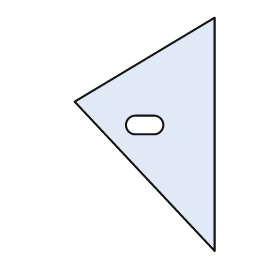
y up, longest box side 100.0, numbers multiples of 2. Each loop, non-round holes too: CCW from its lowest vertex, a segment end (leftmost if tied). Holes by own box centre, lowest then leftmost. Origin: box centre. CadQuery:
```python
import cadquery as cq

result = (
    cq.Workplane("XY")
    .moveTo(30.0, -50.0)
    .lineTo(30.0, 50.0)
    .lineTo(-30.0, 14.0)
    .close()
    .moveTo(-4.0, 0.0)
    .lineTo(4.0, 0.0)
    .threePointArc((8.0, 4.0), (4.0, 8.0))
    .lineTo(-4.0, 8.0)
    .threePointArc((-8.0, 4.0), (-4.0, 0.0))
    .close()
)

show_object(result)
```